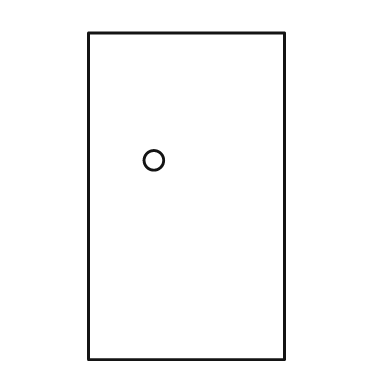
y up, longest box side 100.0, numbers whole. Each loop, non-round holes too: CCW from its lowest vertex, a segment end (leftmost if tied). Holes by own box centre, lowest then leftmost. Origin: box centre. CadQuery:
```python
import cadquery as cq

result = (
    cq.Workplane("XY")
    .moveTo(-30.0, -50.0)
    .lineTo(30.0, -50.0)
    .lineTo(30.0, 50.0)
    .lineTo(-30.0, 50.0)
    .close()
    .moveTo(-10.0, 11.0)
    .circle(3.0)
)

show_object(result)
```